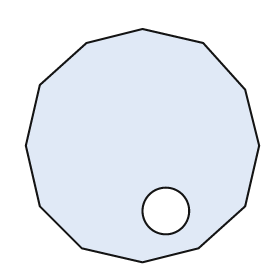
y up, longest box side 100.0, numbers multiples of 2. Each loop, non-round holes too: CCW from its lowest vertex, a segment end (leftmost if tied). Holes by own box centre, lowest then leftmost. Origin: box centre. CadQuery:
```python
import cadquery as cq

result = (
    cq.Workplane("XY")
    .moveTo(0.0, -50.0)
    .lineTo(24.0, -44.0)
    .lineTo(44.0, -26.0)
    .lineTo(50.0, 0.0)
    .lineTo(44.0, 24.0)
    .lineTo(26.0, 44.0)
    .lineTo(0.0, 50.0)
    .lineTo(-24.0, 44.0)
    .lineTo(-44.0, 26.0)
    .lineTo(-50.0, 0.0)
    .lineTo(-44.0, -26.0)
    .lineTo(-26.0, -44.0)
    .close()
    .moveTo(10.0, -28.0)
    .circle(10.0)
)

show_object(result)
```